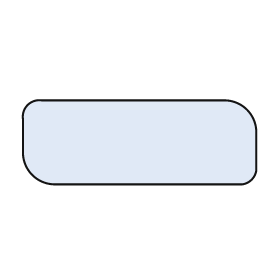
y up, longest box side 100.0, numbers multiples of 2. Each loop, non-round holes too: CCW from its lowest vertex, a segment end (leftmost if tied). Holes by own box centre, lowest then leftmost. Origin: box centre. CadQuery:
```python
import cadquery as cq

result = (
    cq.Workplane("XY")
    .moveTo(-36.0, -18.0)
    .lineTo(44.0, -18.0)
    .threePointArc((48.0, -16.0), (50.0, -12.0))
    .lineTo(50.0, 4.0)
    .threePointArc((46.0, 14.0), (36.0, 18.0))
    .lineTo(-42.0, 18.0)
    .threePointArc((-48.0, 16.0), (-50.0, 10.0))
    .lineTo(-50.0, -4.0)
    .threePointArc((-46.0, -14.0), (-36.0, -18.0))
    .close()
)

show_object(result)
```